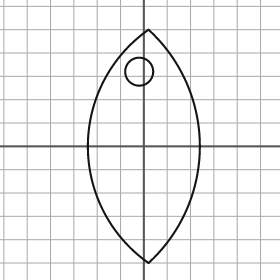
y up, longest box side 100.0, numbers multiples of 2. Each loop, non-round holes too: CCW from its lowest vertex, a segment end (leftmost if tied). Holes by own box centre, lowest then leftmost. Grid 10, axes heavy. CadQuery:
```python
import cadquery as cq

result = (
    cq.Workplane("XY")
    .moveTo(2.0, -50.0)
    .threePointArc((24.0, 0.0), (2.0, 50.0))
    .threePointArc((-24.0, 0.0), (2.0, -50.0))
    .close()
    .moveTo(-2.0, 32.0)
    .circle(6.0)
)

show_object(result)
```